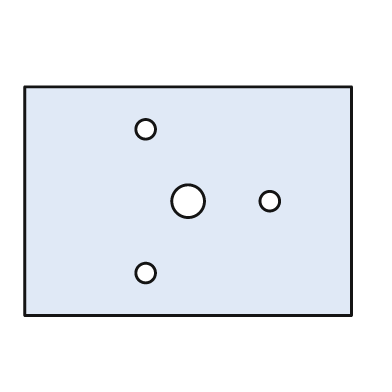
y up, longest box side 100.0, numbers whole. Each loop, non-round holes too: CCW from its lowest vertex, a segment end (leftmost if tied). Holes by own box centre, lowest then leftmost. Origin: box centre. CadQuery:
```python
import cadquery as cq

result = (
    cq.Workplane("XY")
    .moveTo(-50.0, -35.0)
    .lineTo(50.0, -35.0)
    .lineTo(50.0, 35.0)
    .lineTo(-50.0, 35.0)
    .close()
    .moveTo(-13.0, -22.0)
    .circle(3.0)
    .moveTo(0.0, 0.0)
    .circle(5.0)
    .moveTo(25.0, 0.0)
    .circle(3.0)
    .moveTo(-13.0, 22.0)
    .circle(3.0)
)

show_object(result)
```